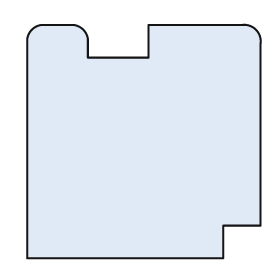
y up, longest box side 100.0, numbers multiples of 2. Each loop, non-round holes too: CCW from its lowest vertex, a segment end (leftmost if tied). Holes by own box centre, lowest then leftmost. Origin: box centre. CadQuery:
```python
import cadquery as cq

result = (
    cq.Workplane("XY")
    .moveTo(-50.0, -50.0)
    .lineTo(34.0, -50.0)
    .lineTo(34.0, -36.0)
    .lineTo(50.0, -36.0)
    .lineTo(50.0, 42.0)
    .threePointArc((48.0, 48.0), (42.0, 50.0))
    .lineTo(2.0, 50.0)
    .lineTo(2.0, 36.0)
    .lineTo(-24.0, 36.0)
    .lineTo(-24.0, 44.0)
    .threePointArc((-26.0, 48.0), (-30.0, 50.0))
    .lineTo(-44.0, 50.0)
    .threePointArc((-48.0, 48.0), (-50.0, 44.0))
    .close()
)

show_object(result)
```